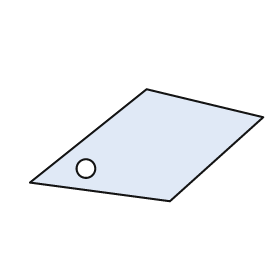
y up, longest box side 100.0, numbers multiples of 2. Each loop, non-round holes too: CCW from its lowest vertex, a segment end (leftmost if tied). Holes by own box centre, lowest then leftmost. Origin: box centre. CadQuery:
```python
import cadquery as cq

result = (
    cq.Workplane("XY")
    .moveTo(10.0, -24.0)
    .lineTo(50.0, 12.0)
    .lineTo(0.0, 24.0)
    .lineTo(-50.0, -16.0)
    .close()
    .moveTo(-26.0, -10.0)
    .circle(4.0)
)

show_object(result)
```